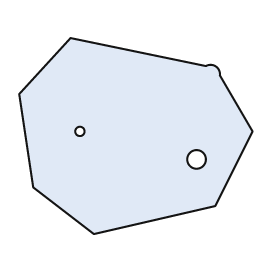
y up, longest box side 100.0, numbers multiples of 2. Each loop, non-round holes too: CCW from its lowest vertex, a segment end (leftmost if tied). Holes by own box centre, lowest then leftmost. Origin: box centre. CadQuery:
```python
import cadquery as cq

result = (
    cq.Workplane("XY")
    .moveTo(-18.0, -42.0)
    .lineTo(34.0, -30.0)
    .lineTo(50.0, 2.0)
    .lineTo(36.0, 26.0)
    .threePointArc((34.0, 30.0), (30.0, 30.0))
    .lineTo(-28.0, 42.0)
    .lineTo(-50.0, 18.0)
    .lineTo(-44.0, -22.0)
    .close()
    .moveTo(26.0, -10.0)
    .circle(4.0)
    .moveTo(-24.0, 2.0)
    .circle(2.0)
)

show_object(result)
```